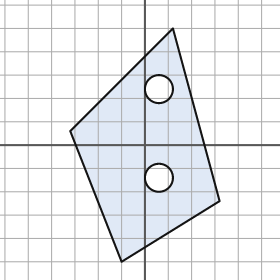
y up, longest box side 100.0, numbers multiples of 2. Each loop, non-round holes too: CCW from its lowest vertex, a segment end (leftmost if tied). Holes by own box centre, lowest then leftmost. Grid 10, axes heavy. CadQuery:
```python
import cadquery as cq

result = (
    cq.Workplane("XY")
    .moveTo(-10.0, -50.0)
    .lineTo(32.0, -24.0)
    .lineTo(12.0, 50.0)
    .lineTo(-32.0, 6.0)
    .close()
    .moveTo(6.0, -14.0)
    .circle(6.0)
    .moveTo(6.0, 24.0)
    .circle(6.0)
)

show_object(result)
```